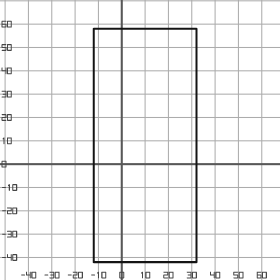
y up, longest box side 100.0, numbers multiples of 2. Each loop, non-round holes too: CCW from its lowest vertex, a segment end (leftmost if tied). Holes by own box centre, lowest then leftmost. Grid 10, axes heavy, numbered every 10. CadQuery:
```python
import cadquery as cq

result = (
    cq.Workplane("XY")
    .moveTo(-12.0, -42.0)
    .lineTo(32.0, -42.0)
    .lineTo(32.0, 58.0)
    .lineTo(-12.0, 58.0)
    .close()
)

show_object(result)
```